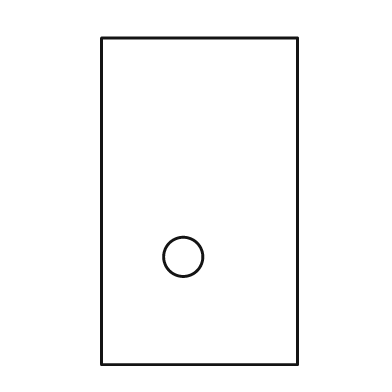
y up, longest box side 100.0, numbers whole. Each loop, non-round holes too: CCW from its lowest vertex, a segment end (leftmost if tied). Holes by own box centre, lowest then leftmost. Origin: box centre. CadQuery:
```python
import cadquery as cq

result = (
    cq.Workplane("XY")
    .moveTo(-30.0, -50.0)
    .lineTo(30.0, -50.0)
    .lineTo(30.0, 50.0)
    .lineTo(-30.0, 50.0)
    .close()
    .moveTo(-5.0, -17.0)
    .circle(6.0)
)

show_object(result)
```